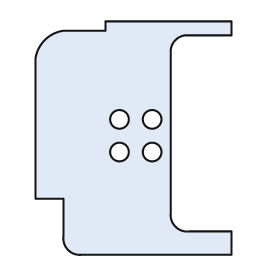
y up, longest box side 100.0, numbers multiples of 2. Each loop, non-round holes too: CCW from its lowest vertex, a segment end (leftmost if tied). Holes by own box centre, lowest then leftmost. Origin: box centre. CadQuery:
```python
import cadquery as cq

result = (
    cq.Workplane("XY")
    .moveTo(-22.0, -50.0)
    .lineTo(42.0, -50.0)
    .lineTo(42.0, -40.0)
    .lineTo(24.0, -40.0)
    .threePointArc((18.0, -38.0), (16.0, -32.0))
    .lineTo(16.0, 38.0)
    .threePointArc((18.0, 42.0), (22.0, 44.0))
    .lineTo(42.0, 44.0)
    .lineTo(42.0, 50.0)
    .lineTo(-12.0, 50.0)
    .lineTo(-12.0, 46.0)
    .lineTo(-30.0, 46.0)
    .threePointArc((-38.0, 42.0), (-42.0, 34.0))
    .lineTo(-42.0, -26.0)
    .lineTo(-30.0, -26.0)
    .lineTo(-30.0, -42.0)
    .threePointArc((-28.0, -48.0), (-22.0, -50.0))
    .close()
    .moveTo(-6.0, -6.0)
    .circle(4.0)
    .moveTo(8.0, -6.0)
    .circle(4.0)
    .moveTo(-6.0, 8.0)
    .circle(4.0)
    .moveTo(8.0, 8.0)
    .circle(4.0)
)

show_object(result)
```